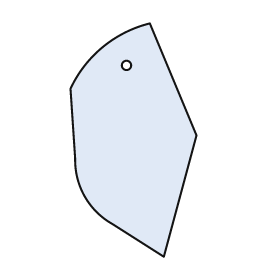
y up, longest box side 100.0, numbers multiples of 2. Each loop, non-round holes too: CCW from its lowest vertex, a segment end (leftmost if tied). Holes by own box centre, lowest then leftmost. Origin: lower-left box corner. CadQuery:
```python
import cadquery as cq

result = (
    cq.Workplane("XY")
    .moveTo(40.0, 0.0)
    .lineTo(54.0, 52.0)
    .lineTo(34.0, 100.0)
    .threePointArc((14.0, 90.0), (0.0, 72.0))
    .lineTo(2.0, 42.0)
    .threePointArc((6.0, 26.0), (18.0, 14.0))
    .close()
    .moveTo(24.0, 82.0)
    .circle(2.0)
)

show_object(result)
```